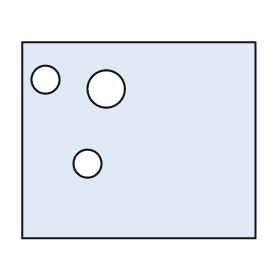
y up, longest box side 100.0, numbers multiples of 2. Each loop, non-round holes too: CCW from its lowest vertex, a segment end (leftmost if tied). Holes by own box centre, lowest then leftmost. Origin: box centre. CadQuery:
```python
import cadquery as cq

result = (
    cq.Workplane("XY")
    .moveTo(-50.0, -42.0)
    .lineTo(50.0, -42.0)
    .lineTo(50.0, 42.0)
    .lineTo(-50.0, 42.0)
    .close()
    .moveTo(-22.0, -10.0)
    .circle(6.0)
    .moveTo(-14.0, 22.0)
    .circle(8.0)
    .moveTo(-40.0, 26.0)
    .circle(6.0)
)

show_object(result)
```